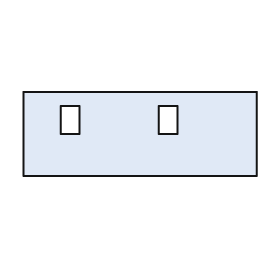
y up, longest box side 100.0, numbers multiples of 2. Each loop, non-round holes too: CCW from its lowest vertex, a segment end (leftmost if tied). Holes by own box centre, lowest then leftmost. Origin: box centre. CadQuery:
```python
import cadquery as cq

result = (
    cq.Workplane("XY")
    .moveTo(-50.0, -18.0)
    .lineTo(50.0, -18.0)
    .lineTo(50.0, 18.0)
    .lineTo(-50.0, 18.0)
    .close()
    .moveTo(-34.0, 0.0)
    .lineTo(-26.0, 0.0)
    .lineTo(-26.0, 12.0)
    .lineTo(-34.0, 12.0)
    .close()
    .moveTo(8.0, 0.0)
    .lineTo(16.0, 0.0)
    .lineTo(16.0, 12.0)
    .lineTo(8.0, 12.0)
    .close()
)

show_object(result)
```